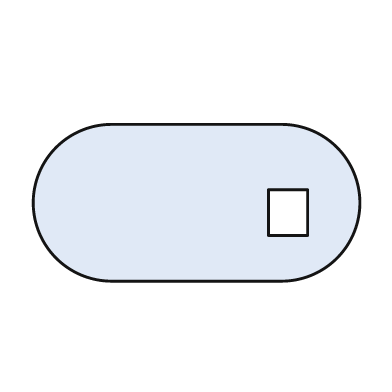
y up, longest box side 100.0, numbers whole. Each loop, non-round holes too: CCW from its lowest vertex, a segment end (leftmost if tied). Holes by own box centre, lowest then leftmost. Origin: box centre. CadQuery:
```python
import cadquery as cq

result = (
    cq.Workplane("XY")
    .moveTo(-26.0, -24.0)
    .lineTo(26.0, -24.0)
    .threePointArc((50.0, 0.0), (26.0, 24.0))
    .lineTo(-26.0, 24.0)
    .threePointArc((-50.0, 0.0), (-26.0, -24.0))
    .close()
    .moveTo(22.0, -10.0)
    .lineTo(34.0, -10.0)
    .lineTo(34.0, 4.0)
    .lineTo(22.0, 4.0)
    .close()
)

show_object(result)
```